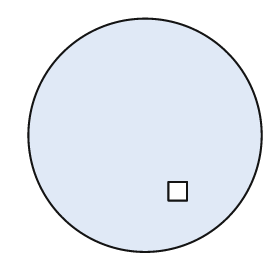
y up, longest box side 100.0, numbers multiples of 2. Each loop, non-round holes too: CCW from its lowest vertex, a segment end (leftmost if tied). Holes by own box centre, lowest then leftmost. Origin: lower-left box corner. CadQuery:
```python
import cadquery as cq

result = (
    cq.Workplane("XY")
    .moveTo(50.0, 50.0)
    .circle(50.0)
    .moveTo(60.0, 22.0)
    .lineTo(68.0, 22.0)
    .lineTo(68.0, 30.0)
    .lineTo(60.0, 30.0)
    .close()
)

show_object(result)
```